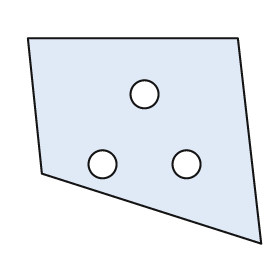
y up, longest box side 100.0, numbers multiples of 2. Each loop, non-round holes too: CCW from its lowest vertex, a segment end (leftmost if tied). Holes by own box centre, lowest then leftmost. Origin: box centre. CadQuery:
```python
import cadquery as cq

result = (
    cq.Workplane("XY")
    .moveTo(50.0, -44.0)
    .lineTo(40.0, 44.0)
    .lineTo(-50.0, 44.0)
    .lineTo(-44.0, -14.0)
    .close()
    .moveTo(-18.0, -10.0)
    .circle(6.0)
    .moveTo(18.0, -10.0)
    .circle(6.0)
    .moveTo(0.0, 20.0)
    .circle(6.0)
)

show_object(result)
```